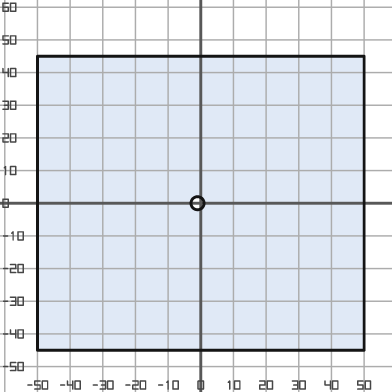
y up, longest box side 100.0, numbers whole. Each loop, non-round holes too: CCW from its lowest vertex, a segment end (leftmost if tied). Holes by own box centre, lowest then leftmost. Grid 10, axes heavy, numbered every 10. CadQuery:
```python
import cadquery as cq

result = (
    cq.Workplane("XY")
    .moveTo(-50.0, -45.0)
    .lineTo(50.0, -45.0)
    .lineTo(50.0, 45.0)
    .lineTo(-50.0, 45.0)
    .close()
    .moveTo(-1.0, 0.0)
    .circle(2.0)
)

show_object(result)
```